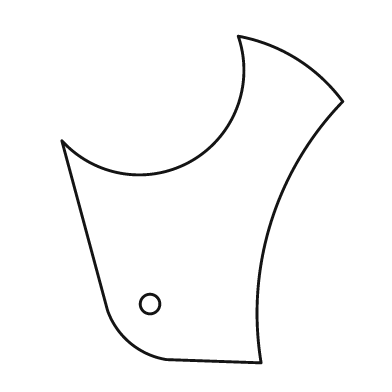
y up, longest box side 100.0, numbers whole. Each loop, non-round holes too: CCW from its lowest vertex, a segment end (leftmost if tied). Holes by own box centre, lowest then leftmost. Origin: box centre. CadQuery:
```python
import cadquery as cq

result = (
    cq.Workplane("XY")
    .moveTo(18.0, -50.0)
    .threePointArc((21.0, -7.0), (43.0, 30.0))
    .threePointArc((29.0, 43.0), (11.0, 50.0))
    .threePointArc((-3.0, 12.0), (-43.0, 18.0))
    .lineTo(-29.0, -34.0)
    .threePointArc((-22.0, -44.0), (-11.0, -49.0))
    .close()
    .moveTo(-16.0, -32.0)
    .circle(3.0)
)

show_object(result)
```